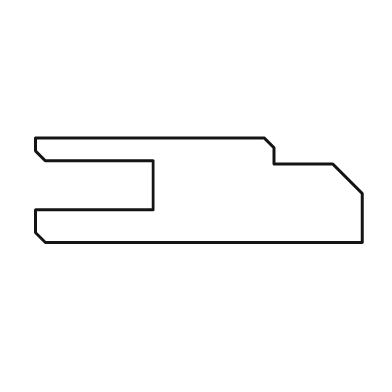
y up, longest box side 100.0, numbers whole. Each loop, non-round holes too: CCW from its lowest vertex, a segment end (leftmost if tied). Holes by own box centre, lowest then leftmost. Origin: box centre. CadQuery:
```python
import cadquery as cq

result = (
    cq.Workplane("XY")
    .moveTo(-47.0, -16.0)
    .lineTo(50.0, -16.0)
    .lineTo(50.0, -1.0)
    .lineTo(41.0, 8.0)
    .lineTo(23.0, 8.0)
    .lineTo(23.0, 13.0)
    .lineTo(20.0, 16.0)
    .lineTo(-50.0, 16.0)
    .lineTo(-50.0, 12.0)
    .lineTo(-47.0, 9.0)
    .lineTo(-14.0, 9.0)
    .lineTo(-14.0, -6.0)
    .lineTo(-50.0, -6.0)
    .lineTo(-50.0, -13.0)
    .close()
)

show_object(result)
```